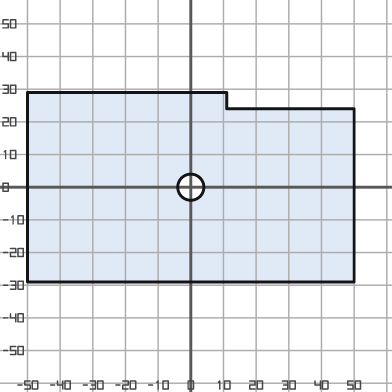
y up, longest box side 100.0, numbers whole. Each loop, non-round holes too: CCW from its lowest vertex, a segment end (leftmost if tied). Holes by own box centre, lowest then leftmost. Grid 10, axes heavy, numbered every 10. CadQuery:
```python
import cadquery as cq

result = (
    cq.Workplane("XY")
    .moveTo(-50.0, -29.0)
    .lineTo(50.0, -29.0)
    .lineTo(50.0, 24.0)
    .lineTo(11.0, 24.0)
    .lineTo(11.0, 29.0)
    .lineTo(-50.0, 29.0)
    .close()
    .moveTo(0.0, 0.0)
    .circle(4.0)
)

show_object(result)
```